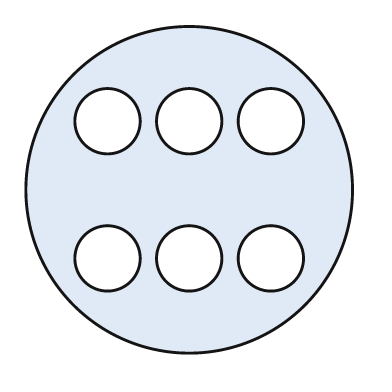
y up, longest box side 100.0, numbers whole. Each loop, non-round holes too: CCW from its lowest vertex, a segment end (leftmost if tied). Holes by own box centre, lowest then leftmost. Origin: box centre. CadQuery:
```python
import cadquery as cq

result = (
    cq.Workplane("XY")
    .moveTo(0.0, 0.0)
    .circle(50.0)
    .moveTo(-25.0, -21.0)
    .circle(10.0)
    .moveTo(0.0, -21.0)
    .circle(10.0)
    .moveTo(25.0, -21.0)
    .circle(10.0)
    .moveTo(-25.0, 21.0)
    .circle(10.0)
    .moveTo(0.0, 21.0)
    .circle(10.0)
    .moveTo(25.0, 21.0)
    .circle(10.0)
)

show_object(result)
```